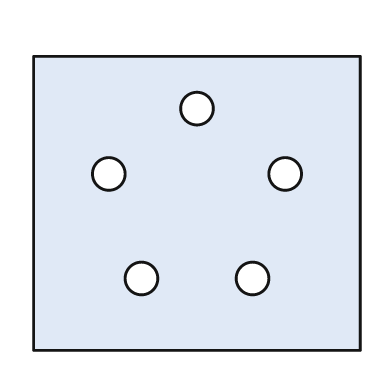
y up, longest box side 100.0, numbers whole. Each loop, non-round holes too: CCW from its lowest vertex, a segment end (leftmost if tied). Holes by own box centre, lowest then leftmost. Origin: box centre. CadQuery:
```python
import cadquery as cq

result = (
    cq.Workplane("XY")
    .moveTo(-50.0, -45.0)
    .lineTo(50.0, -45.0)
    .lineTo(50.0, 45.0)
    .lineTo(-50.0, 45.0)
    .close()
    .moveTo(-17.0, -23.0)
    .circle(5.0)
    .moveTo(17.0, -23.0)
    .circle(5.0)
    .moveTo(-27.0, 9.0)
    .circle(5.0)
    .moveTo(27.0, 9.0)
    .circle(5.0)
    .moveTo(0.0, 29.0)
    .circle(5.0)
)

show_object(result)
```